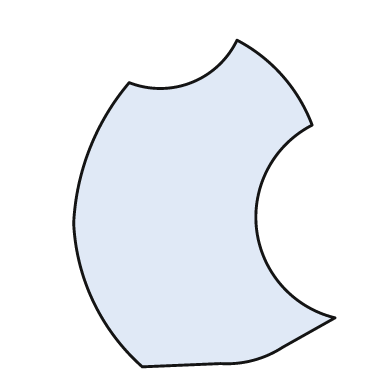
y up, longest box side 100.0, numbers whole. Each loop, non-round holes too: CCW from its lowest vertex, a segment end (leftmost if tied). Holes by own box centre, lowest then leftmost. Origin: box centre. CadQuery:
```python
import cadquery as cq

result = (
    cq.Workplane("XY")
    .moveTo(-19.0, -50.0)
    .lineTo(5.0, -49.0)
    .threePointArc((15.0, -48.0), (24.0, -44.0))
    .lineTo(40.0, -35.0)
    .threePointArc((16.0, -8.0), (33.0, 24.0))
    .threePointArc((24.0, 39.0), (10.0, 50.0))
    .threePointArc((-4.0, 37.0), (-23.0, 37.0))
    .threePointArc((-35.0, 17.0), (-40.0, -6.0))
    .threePointArc((-34.0, -30.0), (-19.0, -50.0))
    .close()
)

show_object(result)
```